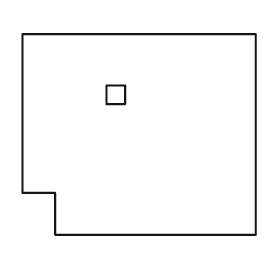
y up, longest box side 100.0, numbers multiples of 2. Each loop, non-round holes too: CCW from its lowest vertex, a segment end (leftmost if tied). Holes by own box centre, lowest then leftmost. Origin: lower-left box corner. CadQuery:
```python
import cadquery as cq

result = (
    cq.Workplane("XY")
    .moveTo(14.0, 0.0)
    .lineTo(100.0, 0.0)
    .lineTo(100.0, 86.0)
    .lineTo(0.0, 86.0)
    .lineTo(0.0, 18.0)
    .lineTo(14.0, 18.0)
    .close()
    .moveTo(36.0, 56.0)
    .lineTo(44.0, 56.0)
    .lineTo(44.0, 64.0)
    .lineTo(36.0, 64.0)
    .close()
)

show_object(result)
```